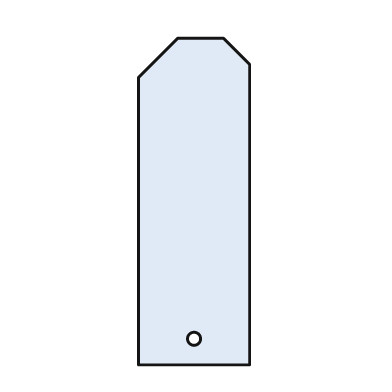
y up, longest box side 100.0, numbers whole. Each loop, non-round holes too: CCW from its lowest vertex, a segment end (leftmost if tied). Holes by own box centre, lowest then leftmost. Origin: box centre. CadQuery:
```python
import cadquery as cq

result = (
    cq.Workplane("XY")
    .moveTo(-17.0, -50.0)
    .lineTo(17.0, -50.0)
    .lineTo(17.0, 42.0)
    .lineTo(9.0, 50.0)
    .lineTo(-5.0, 50.0)
    .lineTo(-17.0, 38.0)
    .close()
    .moveTo(0.0, -42.0)
    .circle(2.0)
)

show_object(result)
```